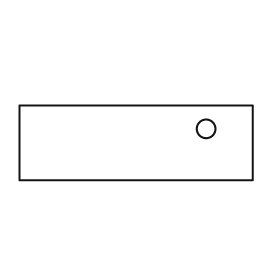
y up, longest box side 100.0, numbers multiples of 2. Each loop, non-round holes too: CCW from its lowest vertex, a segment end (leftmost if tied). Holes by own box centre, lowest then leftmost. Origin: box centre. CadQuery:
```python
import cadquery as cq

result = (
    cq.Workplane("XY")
    .moveTo(-50.0, -16.0)
    .lineTo(50.0, -16.0)
    .lineTo(50.0, 16.0)
    .lineTo(-50.0, 16.0)
    .close()
    .moveTo(30.0, 6.0)
    .circle(4.0)
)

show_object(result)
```